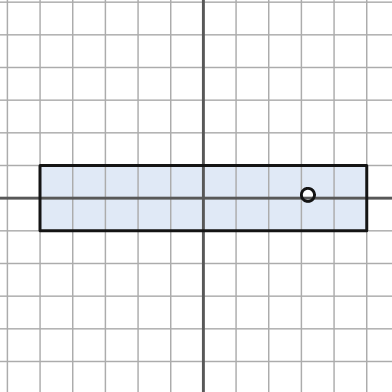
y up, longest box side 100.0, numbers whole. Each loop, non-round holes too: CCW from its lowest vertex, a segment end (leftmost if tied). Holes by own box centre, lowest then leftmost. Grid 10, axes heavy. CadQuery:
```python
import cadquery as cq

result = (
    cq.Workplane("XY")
    .moveTo(-50.0, -10.0)
    .lineTo(50.0, -10.0)
    .lineTo(50.0, 10.0)
    .lineTo(-50.0, 10.0)
    .close()
    .moveTo(32.0, 1.0)
    .circle(2.0)
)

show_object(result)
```